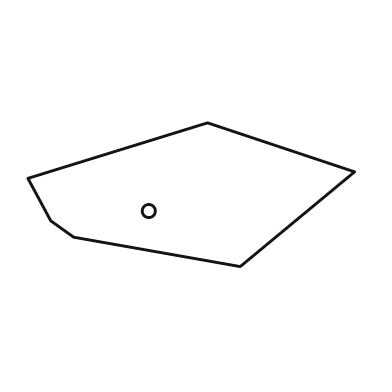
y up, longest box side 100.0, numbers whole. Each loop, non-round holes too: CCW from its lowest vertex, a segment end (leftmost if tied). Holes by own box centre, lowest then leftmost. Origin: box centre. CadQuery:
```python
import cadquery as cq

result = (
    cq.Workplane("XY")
    .moveTo(15.0, -22.0)
    .lineTo(50.0, 7.0)
    .lineTo(5.0, 22.0)
    .lineTo(-50.0, 5.0)
    .lineTo(-43.0, -8.0)
    .lineTo(-36.0, -13.0)
    .close()
    .moveTo(-13.0, -5.0)
    .circle(2.0)
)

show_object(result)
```